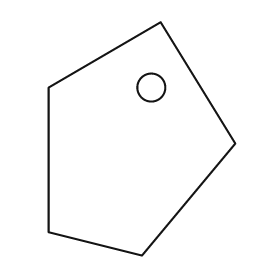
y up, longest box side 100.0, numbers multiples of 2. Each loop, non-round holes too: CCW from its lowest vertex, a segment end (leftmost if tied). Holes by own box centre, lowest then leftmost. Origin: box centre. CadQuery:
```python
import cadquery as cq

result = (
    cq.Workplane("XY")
    .moveTo(0.0, -50.0)
    .lineTo(40.0, -2.0)
    .lineTo(8.0, 50.0)
    .lineTo(-40.0, 22.0)
    .lineTo(-40.0, -40.0)
    .close()
    .moveTo(4.0, 22.0)
    .circle(6.0)
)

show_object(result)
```